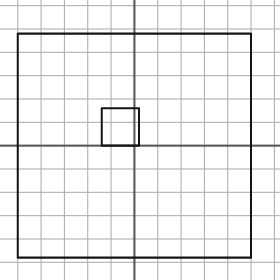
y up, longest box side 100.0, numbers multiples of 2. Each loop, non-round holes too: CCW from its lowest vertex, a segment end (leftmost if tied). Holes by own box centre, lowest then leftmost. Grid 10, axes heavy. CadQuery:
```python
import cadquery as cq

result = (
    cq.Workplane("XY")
    .moveTo(-50.0, -48.0)
    .lineTo(50.0, -48.0)
    .lineTo(50.0, 48.0)
    .lineTo(-50.0, 48.0)
    .close()
    .moveTo(-14.0, 0.0)
    .lineTo(2.0, 0.0)
    .lineTo(2.0, 16.0)
    .lineTo(-14.0, 16.0)
    .close()
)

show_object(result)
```